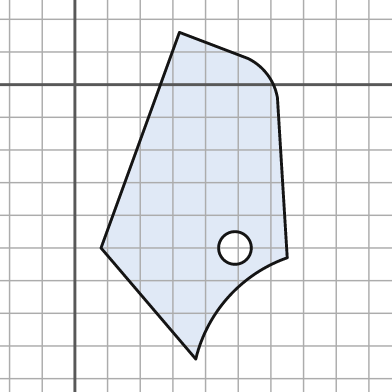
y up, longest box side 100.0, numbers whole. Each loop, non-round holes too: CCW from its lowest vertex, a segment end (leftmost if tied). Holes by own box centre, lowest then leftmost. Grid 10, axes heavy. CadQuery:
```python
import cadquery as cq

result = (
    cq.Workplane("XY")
    .moveTo(37.0, -84.0)
    .threePointArc((47.0, -65.0), (65.0, -53.0))
    .lineTo(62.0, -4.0)
    .threePointArc((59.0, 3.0), (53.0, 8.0))
    .lineTo(32.0, 16.0)
    .lineTo(8.0, -50.0)
    .close()
    .moveTo(49.0, -50.0)
    .circle(5.0)
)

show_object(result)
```